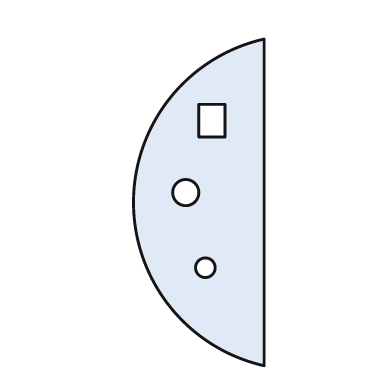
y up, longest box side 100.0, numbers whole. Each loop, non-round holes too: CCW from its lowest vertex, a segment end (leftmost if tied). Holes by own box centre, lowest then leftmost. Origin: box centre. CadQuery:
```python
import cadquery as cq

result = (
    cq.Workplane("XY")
    .moveTo(20.0, -50.0)
    .lineTo(20.0, 50.0)
    .threePointArc((-20.0, 0.0), (20.0, -50.0))
    .close()
    .moveTo(2.0, -20.0)
    .circle(3.0)
    .moveTo(-4.0, 3.0)
    .circle(4.0)
    .moveTo(0.0, 20.0)
    .lineTo(8.0, 20.0)
    .lineTo(8.0, 30.0)
    .lineTo(0.0, 30.0)
    .close()
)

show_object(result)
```